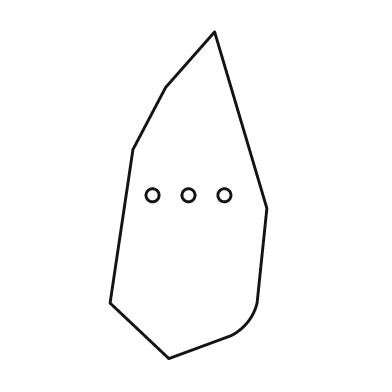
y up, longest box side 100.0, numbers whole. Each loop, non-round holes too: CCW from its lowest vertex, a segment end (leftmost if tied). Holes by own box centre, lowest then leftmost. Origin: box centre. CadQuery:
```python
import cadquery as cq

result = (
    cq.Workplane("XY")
    .moveTo(-6.0, -50.0)
    .lineTo(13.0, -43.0)
    .threePointArc((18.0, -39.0), (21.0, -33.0))
    .lineTo(24.0, -4.0)
    .lineTo(8.0, 50.0)
    .lineTo(-7.0, 33.0)
    .lineTo(-17.0, 14.0)
    .lineTo(-24.0, -33.0)
    .close()
    .moveTo(-11.0, 0.0)
    .circle(2.0)
    .moveTo(0.0, 0.0)
    .circle(2.0)
    .moveTo(11.0, 0.0)
    .circle(2.0)
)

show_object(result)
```